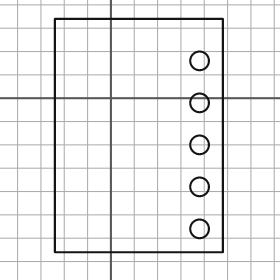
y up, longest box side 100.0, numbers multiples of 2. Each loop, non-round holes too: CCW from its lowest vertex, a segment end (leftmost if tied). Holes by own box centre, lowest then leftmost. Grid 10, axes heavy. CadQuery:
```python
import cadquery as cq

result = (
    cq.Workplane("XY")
    .moveTo(-24.0, -66.0)
    .lineTo(48.0, -66.0)
    .lineTo(48.0, 34.0)
    .lineTo(-24.0, 34.0)
    .close()
    .moveTo(38.0, -56.0)
    .circle(4.0)
    .moveTo(38.0, -38.0)
    .circle(4.0)
    .moveTo(38.0, -20.0)
    .circle(4.0)
    .moveTo(38.0, -2.0)
    .circle(4.0)
    .moveTo(38.0, 16.0)
    .circle(4.0)
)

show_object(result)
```